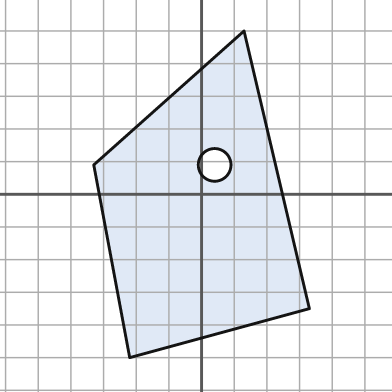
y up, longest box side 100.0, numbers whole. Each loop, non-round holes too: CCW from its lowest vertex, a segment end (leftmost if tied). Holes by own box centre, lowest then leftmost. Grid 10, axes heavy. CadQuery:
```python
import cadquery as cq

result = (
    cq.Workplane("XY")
    .moveTo(-22.0, -50.0)
    .lineTo(33.0, -35.0)
    .lineTo(13.0, 50.0)
    .lineTo(-33.0, 9.0)
    .close()
    .moveTo(4.0, 9.0)
    .circle(5.0)
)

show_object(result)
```